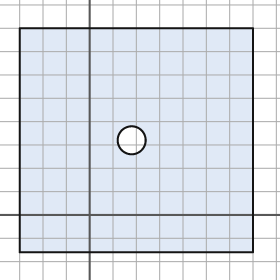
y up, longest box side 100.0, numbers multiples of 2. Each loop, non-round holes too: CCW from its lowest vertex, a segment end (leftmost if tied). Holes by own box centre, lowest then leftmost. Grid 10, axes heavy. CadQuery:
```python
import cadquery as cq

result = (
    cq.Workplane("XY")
    .moveTo(-30.0, -16.0)
    .lineTo(70.0, -16.0)
    .lineTo(70.0, 80.0)
    .lineTo(-30.0, 80.0)
    .close()
    .moveTo(18.0, 32.0)
    .circle(6.0)
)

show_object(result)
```